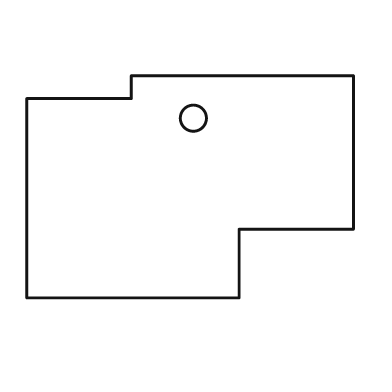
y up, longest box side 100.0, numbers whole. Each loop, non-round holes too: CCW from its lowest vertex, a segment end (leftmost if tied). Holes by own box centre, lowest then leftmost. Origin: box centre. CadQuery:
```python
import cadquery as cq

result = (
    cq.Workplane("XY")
    .moveTo(-50.0, -34.0)
    .lineTo(15.0, -34.0)
    .lineTo(15.0, -13.0)
    .lineTo(50.0, -13.0)
    .lineTo(50.0, 34.0)
    .lineTo(-18.0, 34.0)
    .lineTo(-18.0, 27.0)
    .lineTo(-50.0, 27.0)
    .close()
    .moveTo(1.0, 21.0)
    .circle(4.0)
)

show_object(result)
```